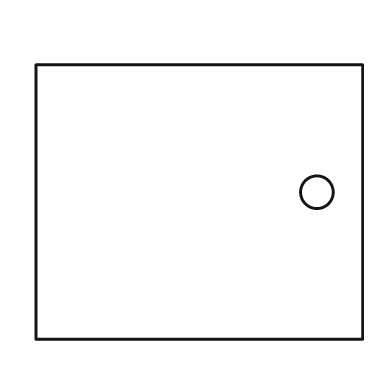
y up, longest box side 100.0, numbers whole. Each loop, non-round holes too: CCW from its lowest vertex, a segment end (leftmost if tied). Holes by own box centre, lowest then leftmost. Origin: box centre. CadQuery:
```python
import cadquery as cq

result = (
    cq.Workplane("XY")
    .moveTo(-50.0, -42.0)
    .lineTo(50.0, -42.0)
    .lineTo(50.0, 42.0)
    .lineTo(-50.0, 42.0)
    .close()
    .moveTo(36.0, 3.0)
    .circle(5.0)
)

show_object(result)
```